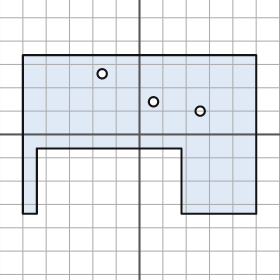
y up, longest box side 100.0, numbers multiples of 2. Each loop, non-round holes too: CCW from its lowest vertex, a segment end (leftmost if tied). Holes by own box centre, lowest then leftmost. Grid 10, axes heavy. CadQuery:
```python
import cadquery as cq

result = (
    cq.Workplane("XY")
    .moveTo(-50.0, -34.0)
    .lineTo(-44.0, -34.0)
    .lineTo(-44.0, -6.0)
    .lineTo(18.0, -6.0)
    .lineTo(18.0, -34.0)
    .lineTo(50.0, -34.0)
    .lineTo(50.0, 34.0)
    .lineTo(-50.0, 34.0)
    .close()
    .moveTo(26.0, 10.0)
    .circle(2.0)
    .moveTo(6.0, 14.0)
    .circle(2.0)
    .moveTo(-16.0, 26.0)
    .circle(2.0)
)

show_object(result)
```